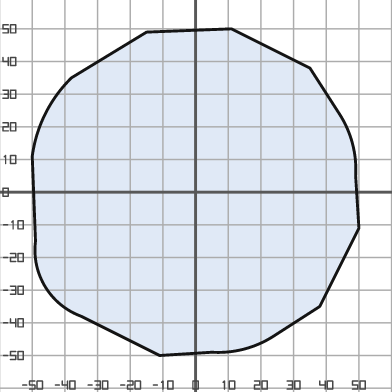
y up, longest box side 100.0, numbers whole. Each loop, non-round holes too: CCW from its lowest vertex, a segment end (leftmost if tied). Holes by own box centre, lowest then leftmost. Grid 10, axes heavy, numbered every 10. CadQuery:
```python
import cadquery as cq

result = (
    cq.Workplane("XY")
    .moveTo(-11.0, -50.0)
    .lineTo(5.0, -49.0)
    .threePointArc((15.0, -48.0), (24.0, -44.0))
    .lineTo(38.0, -35.0)
    .lineTo(50.0, -11.0)
    .lineTo(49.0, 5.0)
    .threePointArc((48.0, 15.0), (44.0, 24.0))
    .lineTo(35.0, 38.0)
    .lineTo(11.0, 50.0)
    .lineTo(-15.0, 49.0)
    .lineTo(-38.0, 35.0)
    .threePointArc((-46.0, 24.0), (-50.0, 11.0))
    .lineTo(-49.0, -15.0)
    .threePointArc((-46.0, -29.0), (-35.0, -38.0))
    .close()
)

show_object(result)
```